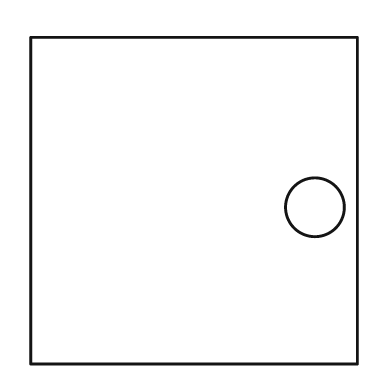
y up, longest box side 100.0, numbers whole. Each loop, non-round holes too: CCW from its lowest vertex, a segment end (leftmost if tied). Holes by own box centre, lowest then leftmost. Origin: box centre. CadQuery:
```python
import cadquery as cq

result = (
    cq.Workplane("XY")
    .moveTo(-50.0, -50.0)
    .lineTo(50.0, -50.0)
    .lineTo(50.0, 50.0)
    .lineTo(-50.0, 50.0)
    .close()
    .moveTo(37.0, -2.0)
    .circle(9.0)
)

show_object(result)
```